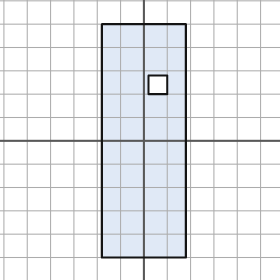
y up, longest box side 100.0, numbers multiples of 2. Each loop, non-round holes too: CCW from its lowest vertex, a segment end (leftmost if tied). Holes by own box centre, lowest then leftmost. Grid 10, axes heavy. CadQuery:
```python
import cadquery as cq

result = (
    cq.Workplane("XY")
    .moveTo(-18.0, -50.0)
    .lineTo(18.0, -50.0)
    .lineTo(18.0, 50.0)
    .lineTo(-18.0, 50.0)
    .close()
    .moveTo(2.0, 20.0)
    .lineTo(10.0, 20.0)
    .lineTo(10.0, 28.0)
    .lineTo(2.0, 28.0)
    .close()
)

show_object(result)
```